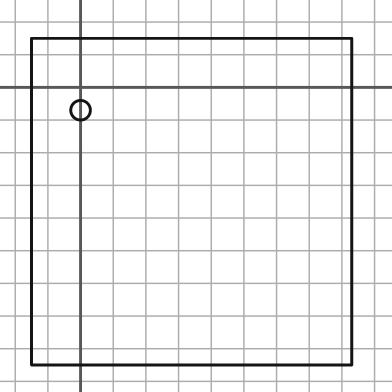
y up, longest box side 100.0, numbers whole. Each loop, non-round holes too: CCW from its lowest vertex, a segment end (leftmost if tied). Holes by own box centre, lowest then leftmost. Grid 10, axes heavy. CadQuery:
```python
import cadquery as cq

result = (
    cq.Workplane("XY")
    .moveTo(-15.0, -85.0)
    .lineTo(83.0, -85.0)
    .lineTo(83.0, 15.0)
    .lineTo(-15.0, 15.0)
    .close()
    .moveTo(0.0, -7.0)
    .circle(3.0)
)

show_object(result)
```